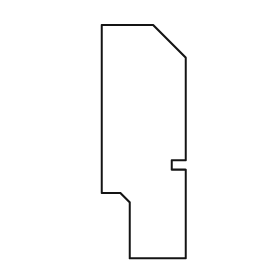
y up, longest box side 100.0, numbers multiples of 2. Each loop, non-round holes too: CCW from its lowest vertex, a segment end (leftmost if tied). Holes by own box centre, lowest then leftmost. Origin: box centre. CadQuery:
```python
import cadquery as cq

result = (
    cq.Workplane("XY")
    .moveTo(-6.0, -50.0)
    .lineTo(18.0, -50.0)
    .lineTo(18.0, -12.0)
    .lineTo(12.0, -12.0)
    .lineTo(12.0, -8.0)
    .lineTo(18.0, -8.0)
    .lineTo(18.0, 36.0)
    .lineTo(4.0, 50.0)
    .lineTo(-18.0, 50.0)
    .lineTo(-18.0, -22.0)
    .lineTo(-10.0, -22.0)
    .lineTo(-6.0, -26.0)
    .close()
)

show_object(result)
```